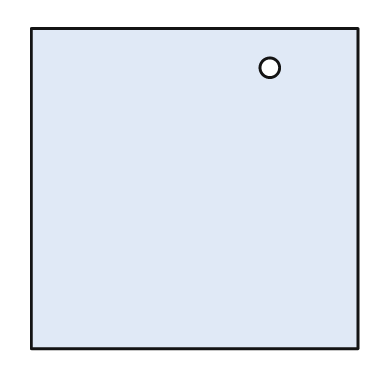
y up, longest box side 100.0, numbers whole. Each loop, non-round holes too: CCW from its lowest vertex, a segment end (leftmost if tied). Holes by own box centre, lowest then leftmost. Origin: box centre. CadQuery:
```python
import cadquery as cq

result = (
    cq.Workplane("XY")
    .moveTo(-50.0, -49.0)
    .lineTo(50.0, -49.0)
    .lineTo(50.0, 49.0)
    .lineTo(-50.0, 49.0)
    .close()
    .moveTo(23.0, 37.0)
    .circle(3.0)
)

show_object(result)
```